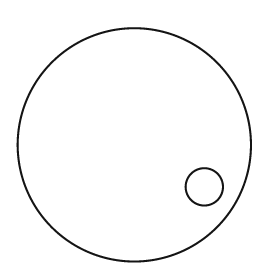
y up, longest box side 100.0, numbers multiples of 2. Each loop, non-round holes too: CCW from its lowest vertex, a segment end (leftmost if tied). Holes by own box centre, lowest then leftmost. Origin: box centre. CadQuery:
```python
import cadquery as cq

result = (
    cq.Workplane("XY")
    .moveTo(0.0, 0.0)
    .circle(50.0)
    .moveTo(30.0, -18.0)
    .circle(8.0)
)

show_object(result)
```